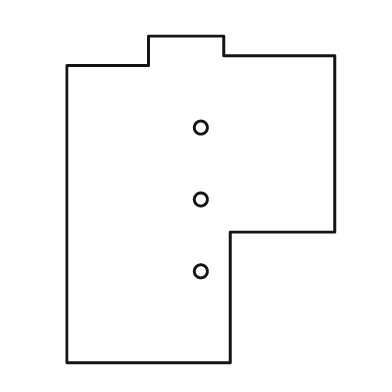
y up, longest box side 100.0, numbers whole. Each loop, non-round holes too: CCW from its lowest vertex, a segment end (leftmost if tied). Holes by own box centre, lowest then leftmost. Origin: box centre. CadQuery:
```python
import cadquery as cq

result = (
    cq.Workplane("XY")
    .moveTo(-41.0, -50.0)
    .lineTo(9.0, -50.0)
    .lineTo(9.0, -10.0)
    .lineTo(41.0, -10.0)
    .lineTo(41.0, 44.0)
    .lineTo(7.0, 44.0)
    .lineTo(7.0, 50.0)
    .lineTo(-16.0, 50.0)
    .lineTo(-16.0, 41.0)
    .lineTo(-41.0, 41.0)
    .close()
    .moveTo(0.0, -22.0)
    .circle(2.0)
    .moveTo(0.0, 0.0)
    .circle(2.0)
    .moveTo(0.0, 22.0)
    .circle(2.0)
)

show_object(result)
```